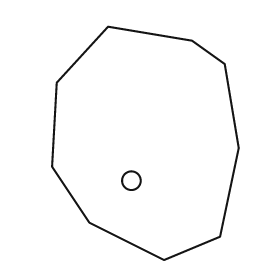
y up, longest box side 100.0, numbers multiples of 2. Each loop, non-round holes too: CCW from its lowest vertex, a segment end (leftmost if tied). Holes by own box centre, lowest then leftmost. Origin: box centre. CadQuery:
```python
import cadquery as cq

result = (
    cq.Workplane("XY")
    .moveTo(8.0, -50.0)
    .lineTo(32.0, -40.0)
    .lineTo(40.0, -2.0)
    .lineTo(34.0, 34.0)
    .lineTo(20.0, 44.0)
    .lineTo(-16.0, 50.0)
    .lineTo(-38.0, 26.0)
    .lineTo(-40.0, -10.0)
    .lineTo(-24.0, -34.0)
    .close()
    .moveTo(-6.0, -16.0)
    .circle(4.0)
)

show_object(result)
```